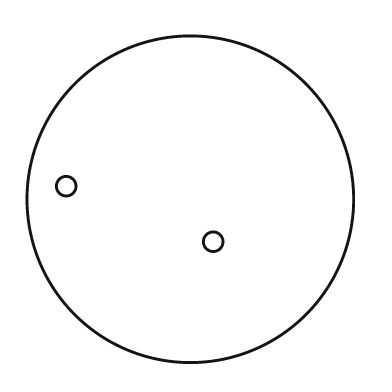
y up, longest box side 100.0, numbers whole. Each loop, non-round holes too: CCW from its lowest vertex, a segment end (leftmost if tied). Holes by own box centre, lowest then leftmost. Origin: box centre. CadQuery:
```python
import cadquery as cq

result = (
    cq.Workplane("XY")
    .moveTo(0.0, 0.0)
    .circle(50.0)
    .moveTo(7.0, -13.0)
    .circle(3.0)
    .moveTo(-38.0, 4.0)
    .circle(3.0)
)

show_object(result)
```